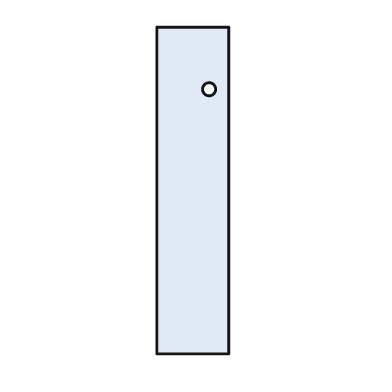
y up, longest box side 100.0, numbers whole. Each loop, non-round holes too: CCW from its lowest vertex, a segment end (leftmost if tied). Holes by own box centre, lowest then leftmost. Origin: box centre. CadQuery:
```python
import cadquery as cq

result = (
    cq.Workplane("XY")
    .moveTo(-11.0, -50.0)
    .lineTo(11.0, -50.0)
    .lineTo(11.0, 50.0)
    .lineTo(-11.0, 50.0)
    .close()
    .moveTo(5.0, 31.0)
    .circle(2.0)
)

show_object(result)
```